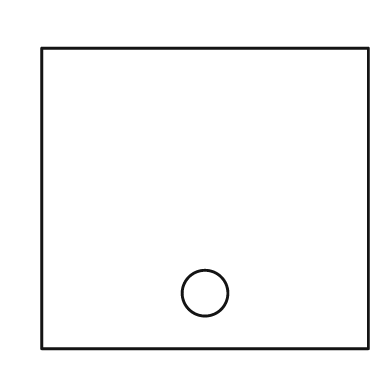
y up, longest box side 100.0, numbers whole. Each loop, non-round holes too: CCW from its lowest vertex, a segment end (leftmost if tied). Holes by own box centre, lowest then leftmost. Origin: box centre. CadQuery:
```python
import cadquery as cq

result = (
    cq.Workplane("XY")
    .moveTo(-50.0, -46.0)
    .lineTo(50.0, -46.0)
    .lineTo(50.0, 46.0)
    .lineTo(-50.0, 46.0)
    .close()
    .moveTo(0.0, -29.0)
    .circle(7.0)
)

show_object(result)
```